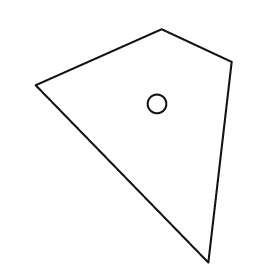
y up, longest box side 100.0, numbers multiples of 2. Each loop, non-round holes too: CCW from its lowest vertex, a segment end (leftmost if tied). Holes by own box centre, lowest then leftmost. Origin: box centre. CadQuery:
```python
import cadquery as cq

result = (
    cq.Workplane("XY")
    .moveTo(32.0, -50.0)
    .lineTo(42.0, 36.0)
    .lineTo(12.0, 50.0)
    .lineTo(-42.0, 26.0)
    .close()
    .moveTo(10.0, 18.0)
    .circle(4.0)
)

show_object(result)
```